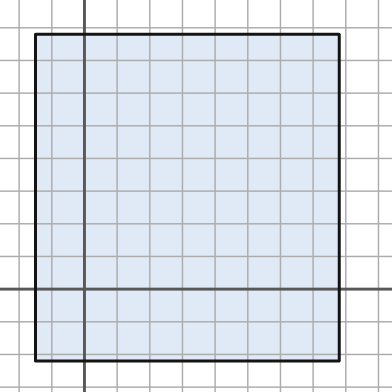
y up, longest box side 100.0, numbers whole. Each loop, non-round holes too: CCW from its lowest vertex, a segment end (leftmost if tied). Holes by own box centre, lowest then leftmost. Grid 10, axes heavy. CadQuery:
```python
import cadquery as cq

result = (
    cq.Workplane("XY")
    .moveTo(-15.0, -22.0)
    .lineTo(78.0, -22.0)
    .lineTo(78.0, 78.0)
    .lineTo(-15.0, 78.0)
    .close()
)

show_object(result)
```